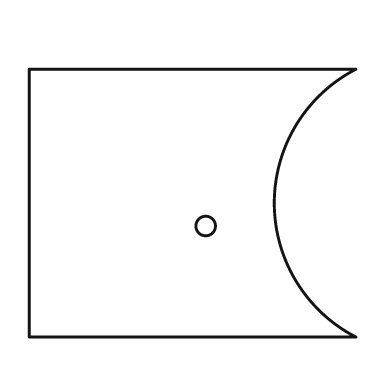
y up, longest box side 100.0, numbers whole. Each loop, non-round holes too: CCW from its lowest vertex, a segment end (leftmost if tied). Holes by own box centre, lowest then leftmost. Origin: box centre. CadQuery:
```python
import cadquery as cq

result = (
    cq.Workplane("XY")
    .moveTo(-50.0, -41.0)
    .lineTo(50.0, -41.0)
    .threePointArc((25.0, 0.0), (50.0, 41.0))
    .lineTo(-50.0, 41.0)
    .close()
    .moveTo(4.0, -7.0)
    .circle(3.0)
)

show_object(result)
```